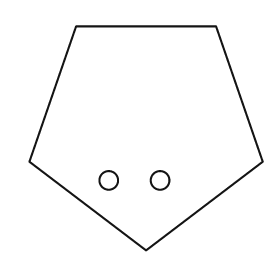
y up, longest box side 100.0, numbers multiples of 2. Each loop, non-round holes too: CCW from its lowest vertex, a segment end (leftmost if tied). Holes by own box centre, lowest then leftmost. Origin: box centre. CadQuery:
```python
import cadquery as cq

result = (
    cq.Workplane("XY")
    .moveTo(0.0, -48.0)
    .lineTo(50.0, -10.0)
    .lineTo(30.0, 48.0)
    .lineTo(-30.0, 48.0)
    .lineTo(-50.0, -10.0)
    .close()
    .moveTo(-16.0, -18.0)
    .circle(4.0)
    .moveTo(6.0, -18.0)
    .circle(4.0)
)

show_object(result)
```